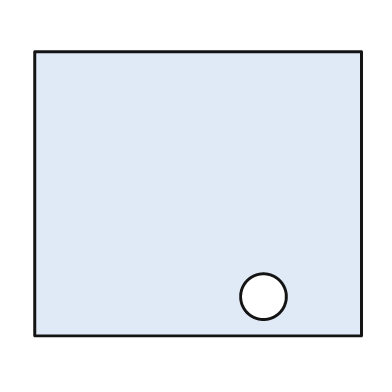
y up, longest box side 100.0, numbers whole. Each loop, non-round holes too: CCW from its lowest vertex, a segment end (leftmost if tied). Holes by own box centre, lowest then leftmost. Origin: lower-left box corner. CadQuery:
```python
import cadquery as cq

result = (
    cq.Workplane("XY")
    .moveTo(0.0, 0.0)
    .lineTo(100.0, 0.0)
    .lineTo(100.0, 87.0)
    .lineTo(0.0, 87.0)
    .close()
    .moveTo(70.0, 12.0)
    .circle(7.0)
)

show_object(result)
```